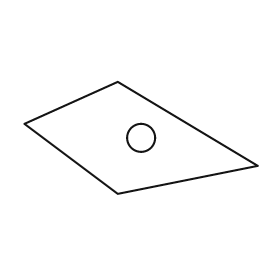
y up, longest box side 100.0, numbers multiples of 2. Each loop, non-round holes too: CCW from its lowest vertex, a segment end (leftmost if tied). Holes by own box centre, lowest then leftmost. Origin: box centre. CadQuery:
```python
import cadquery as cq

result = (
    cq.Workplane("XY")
    .moveTo(-10.0, -24.0)
    .lineTo(50.0, -12.0)
    .lineTo(-10.0, 24.0)
    .lineTo(-50.0, 6.0)
    .close()
    .moveTo(0.0, 0.0)
    .circle(6.0)
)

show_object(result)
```